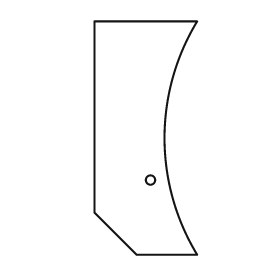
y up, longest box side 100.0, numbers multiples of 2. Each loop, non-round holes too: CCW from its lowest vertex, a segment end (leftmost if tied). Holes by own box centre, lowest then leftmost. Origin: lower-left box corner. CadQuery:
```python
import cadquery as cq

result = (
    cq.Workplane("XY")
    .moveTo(18.0, 0.0)
    .lineTo(44.0, 0.0)
    .threePointArc((30.0, 50.0), (44.0, 100.0))
    .lineTo(0.0, 100.0)
    .lineTo(0.0, 18.0)
    .close()
    .moveTo(24.0, 32.0)
    .circle(2.0)
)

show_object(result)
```